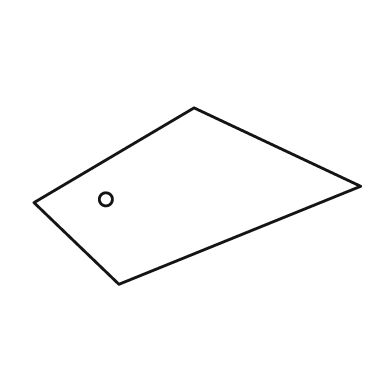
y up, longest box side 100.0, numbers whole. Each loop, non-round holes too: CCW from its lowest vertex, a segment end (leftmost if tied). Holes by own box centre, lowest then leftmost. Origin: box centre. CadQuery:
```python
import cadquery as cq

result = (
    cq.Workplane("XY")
    .moveTo(-24.0, -27.0)
    .lineTo(50.0, 3.0)
    .lineTo(-1.0, 27.0)
    .lineTo(-50.0, -2.0)
    .close()
    .moveTo(-28.0, -1.0)
    .circle(2.0)
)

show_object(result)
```